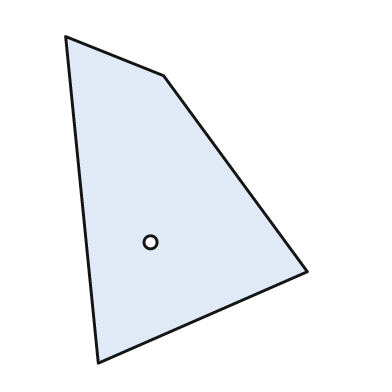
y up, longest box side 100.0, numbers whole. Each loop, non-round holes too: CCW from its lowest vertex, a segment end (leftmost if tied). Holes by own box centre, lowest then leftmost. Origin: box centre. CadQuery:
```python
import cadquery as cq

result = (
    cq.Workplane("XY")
    .moveTo(-27.0, -50.0)
    .lineTo(37.0, -22.0)
    .lineTo(-7.0, 38.0)
    .lineTo(-37.0, 50.0)
    .close()
    .moveTo(-11.0, -13.0)
    .circle(2.0)
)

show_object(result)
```